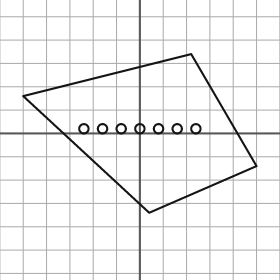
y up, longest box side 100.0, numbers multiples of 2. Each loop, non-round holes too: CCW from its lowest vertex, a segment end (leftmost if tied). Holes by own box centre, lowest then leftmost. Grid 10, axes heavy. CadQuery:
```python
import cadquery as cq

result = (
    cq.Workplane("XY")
    .moveTo(4.0, -34.0)
    .lineTo(50.0, -14.0)
    .lineTo(22.0, 34.0)
    .lineTo(-50.0, 16.0)
    .close()
    .moveTo(-24.0, 2.0)
    .circle(2.0)
    .moveTo(-16.0, 2.0)
    .circle(2.0)
    .moveTo(-8.0, 2.0)
    .circle(2.0)
    .moveTo(0.0, 2.0)
    .circle(2.0)
    .moveTo(8.0, 2.0)
    .circle(2.0)
    .moveTo(16.0, 2.0)
    .circle(2.0)
    .moveTo(24.0, 2.0)
    .circle(2.0)
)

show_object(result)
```